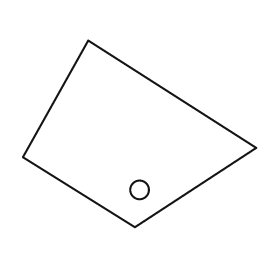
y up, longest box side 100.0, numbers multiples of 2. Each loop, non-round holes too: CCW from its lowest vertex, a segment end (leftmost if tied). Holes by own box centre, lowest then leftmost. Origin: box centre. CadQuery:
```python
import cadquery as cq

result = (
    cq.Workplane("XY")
    .moveTo(-2.0, -40.0)
    .lineTo(50.0, -6.0)
    .lineTo(-22.0, 40.0)
    .lineTo(-50.0, -10.0)
    .close()
    .moveTo(0.0, -24.0)
    .circle(4.0)
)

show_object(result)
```